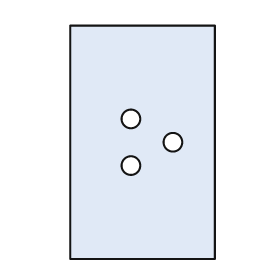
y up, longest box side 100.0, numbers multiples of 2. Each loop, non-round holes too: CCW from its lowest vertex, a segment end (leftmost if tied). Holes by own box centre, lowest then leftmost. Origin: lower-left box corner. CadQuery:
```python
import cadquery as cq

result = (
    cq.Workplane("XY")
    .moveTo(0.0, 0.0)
    .lineTo(62.0, 0.0)
    .lineTo(62.0, 100.0)
    .lineTo(0.0, 100.0)
    .close()
    .moveTo(26.0, 40.0)
    .circle(4.0)
    .moveTo(44.0, 50.0)
    .circle(4.0)
    .moveTo(26.0, 60.0)
    .circle(4.0)
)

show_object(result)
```